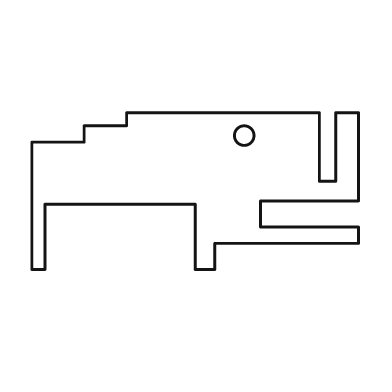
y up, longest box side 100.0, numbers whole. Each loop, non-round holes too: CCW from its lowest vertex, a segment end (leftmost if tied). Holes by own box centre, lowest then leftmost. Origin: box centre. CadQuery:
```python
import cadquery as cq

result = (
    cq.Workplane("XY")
    .moveTo(-50.0, -24.0)
    .lineTo(-46.0, -24.0)
    .lineTo(-46.0, -4.0)
    .lineTo(0.0, -4.0)
    .lineTo(0.0, -24.0)
    .lineTo(6.0, -24.0)
    .lineTo(6.0, -16.0)
    .lineTo(50.0, -16.0)
    .lineTo(50.0, -11.0)
    .lineTo(20.0, -11.0)
    .lineTo(20.0, -3.0)
    .lineTo(50.0, -3.0)
    .lineTo(50.0, 24.0)
    .lineTo(43.0, 24.0)
    .lineTo(43.0, 3.0)
    .lineTo(38.0, 3.0)
    .lineTo(38.0, 24.0)
    .lineTo(-21.0, 24.0)
    .lineTo(-21.0, 20.0)
    .lineTo(-34.0, 20.0)
    .lineTo(-34.0, 15.0)
    .lineTo(-50.0, 15.0)
    .close()
    .moveTo(15.0, 17.0)
    .circle(3.0)
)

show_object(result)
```